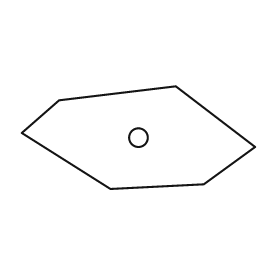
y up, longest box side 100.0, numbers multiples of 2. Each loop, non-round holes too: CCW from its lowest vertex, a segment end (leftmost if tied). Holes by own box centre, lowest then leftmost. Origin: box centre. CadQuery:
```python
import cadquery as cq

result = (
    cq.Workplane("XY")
    .moveTo(-12.0, -22.0)
    .lineTo(28.0, -20.0)
    .lineTo(50.0, -4.0)
    .lineTo(16.0, 22.0)
    .lineTo(-34.0, 16.0)
    .lineTo(-50.0, 2.0)
    .close()
    .moveTo(0.0, 0.0)
    .circle(4.0)
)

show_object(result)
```